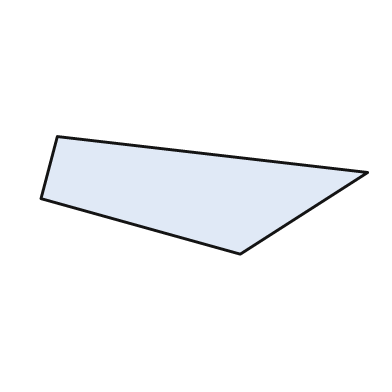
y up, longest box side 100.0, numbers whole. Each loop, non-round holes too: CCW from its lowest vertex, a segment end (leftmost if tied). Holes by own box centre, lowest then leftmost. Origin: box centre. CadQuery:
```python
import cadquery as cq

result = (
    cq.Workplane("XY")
    .moveTo(11.0, -18.0)
    .lineTo(50.0, 7.0)
    .lineTo(-45.0, 18.0)
    .lineTo(-50.0, -1.0)
    .close()
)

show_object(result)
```